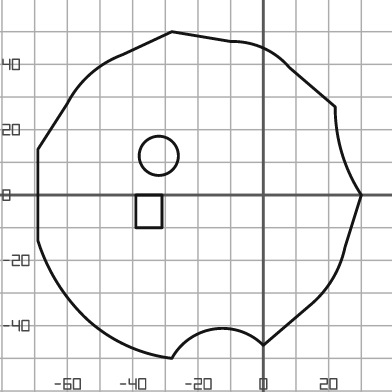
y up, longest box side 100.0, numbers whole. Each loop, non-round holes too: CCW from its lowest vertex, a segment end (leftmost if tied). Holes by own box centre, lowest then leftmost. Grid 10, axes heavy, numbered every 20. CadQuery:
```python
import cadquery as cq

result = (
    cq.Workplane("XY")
    .moveTo(-28.0, -50.0)
    .threePointArc((-15.0, -41.0), (0.0, -46.0))
    .lineTo(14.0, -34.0)
    .threePointArc((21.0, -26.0), (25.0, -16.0))
    .lineTo(30.0, 0.0)
    .threePointArc((24.0, 13.0), (22.0, 27.0))
    .lineTo(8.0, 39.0)
    .threePointArc((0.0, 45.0), (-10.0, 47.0))
    .lineTo(-28.0, 50.0)
    .lineTo(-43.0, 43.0)
    .threePointArc((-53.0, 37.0), (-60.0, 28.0))
    .lineTo(-69.0, 14.0)
    .lineTo(-69.0, -14.0)
    .threePointArc((-63.0, -27.0), (-54.0, -38.0))
    .threePointArc((-42.0, -46.0), (-28.0, -50.0))
    .close()
    .moveTo(-39.0, -10.0)
    .lineTo(-31.0, -10.0)
    .lineTo(-31.0, 0.0)
    .lineTo(-39.0, 0.0)
    .close()
    .moveTo(-32.0, 12.0)
    .circle(6.0)
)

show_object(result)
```